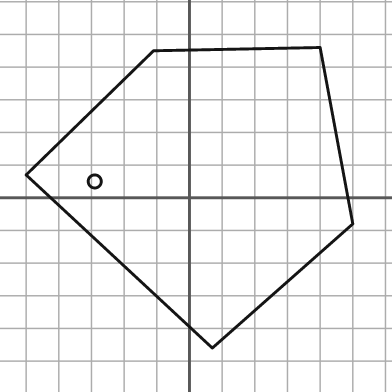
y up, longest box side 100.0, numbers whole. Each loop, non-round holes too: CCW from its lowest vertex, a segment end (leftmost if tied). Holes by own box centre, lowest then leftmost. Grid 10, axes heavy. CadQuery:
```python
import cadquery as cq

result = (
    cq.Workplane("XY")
    .moveTo(7.0, -46.0)
    .lineTo(50.0, -8.0)
    .lineTo(40.0, 46.0)
    .lineTo(-11.0, 45.0)
    .lineTo(-50.0, 7.0)
    .close()
    .moveTo(-29.0, 5.0)
    .circle(2.0)
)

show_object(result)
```